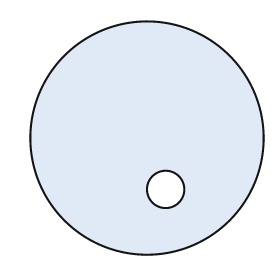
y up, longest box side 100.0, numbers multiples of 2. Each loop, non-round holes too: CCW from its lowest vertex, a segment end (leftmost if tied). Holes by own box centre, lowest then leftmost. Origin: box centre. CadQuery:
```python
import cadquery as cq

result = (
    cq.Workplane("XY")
    .moveTo(0.0, 0.0)
    .circle(50.0)
    .moveTo(8.0, -22.0)
    .circle(8.0)
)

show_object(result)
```